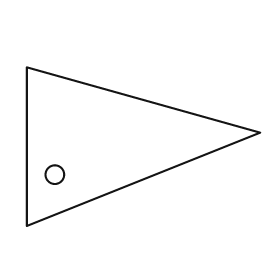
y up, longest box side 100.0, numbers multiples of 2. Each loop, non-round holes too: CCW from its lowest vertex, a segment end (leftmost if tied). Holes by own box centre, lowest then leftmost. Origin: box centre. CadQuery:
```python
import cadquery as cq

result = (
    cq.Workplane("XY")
    .moveTo(-50.0, -34.0)
    .lineTo(50.0, 6.0)
    .lineTo(-50.0, 34.0)
    .close()
    .moveTo(-38.0, -12.0)
    .circle(4.0)
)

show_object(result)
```